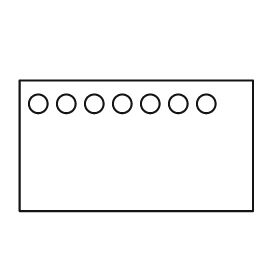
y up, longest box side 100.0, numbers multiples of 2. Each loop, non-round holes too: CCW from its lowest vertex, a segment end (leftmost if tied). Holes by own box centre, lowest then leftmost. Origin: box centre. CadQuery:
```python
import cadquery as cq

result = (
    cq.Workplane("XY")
    .moveTo(-50.0, -28.0)
    .lineTo(50.0, -28.0)
    .lineTo(50.0, 28.0)
    .lineTo(-50.0, 28.0)
    .close()
    .moveTo(-42.0, 18.0)
    .circle(4.0)
    .moveTo(-30.0, 18.0)
    .circle(4.0)
    .moveTo(-18.0, 18.0)
    .circle(4.0)
    .moveTo(-6.0, 18.0)
    .circle(4.0)
    .moveTo(6.0, 18.0)
    .circle(4.0)
    .moveTo(18.0, 18.0)
    .circle(4.0)
    .moveTo(30.0, 18.0)
    .circle(4.0)
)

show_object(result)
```